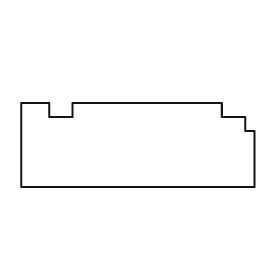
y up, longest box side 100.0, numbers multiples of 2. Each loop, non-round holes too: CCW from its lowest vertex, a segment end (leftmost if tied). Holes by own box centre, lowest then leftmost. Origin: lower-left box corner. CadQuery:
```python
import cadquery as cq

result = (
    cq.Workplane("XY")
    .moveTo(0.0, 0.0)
    .lineTo(100.0, 0.0)
    .lineTo(100.0, 24.0)
    .lineTo(96.0, 24.0)
    .lineTo(96.0, 30.0)
    .lineTo(86.0, 30.0)
    .lineTo(86.0, 36.0)
    .lineTo(22.0, 36.0)
    .lineTo(22.0, 30.0)
    .lineTo(12.0, 30.0)
    .lineTo(12.0, 36.0)
    .lineTo(0.0, 36.0)
    .close()
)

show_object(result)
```